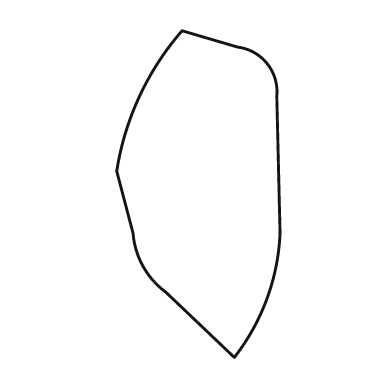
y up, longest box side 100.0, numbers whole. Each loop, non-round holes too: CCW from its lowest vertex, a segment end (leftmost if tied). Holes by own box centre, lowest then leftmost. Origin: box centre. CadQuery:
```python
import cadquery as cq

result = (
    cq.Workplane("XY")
    .moveTo(11.0, -50.0)
    .threePointArc((21.0, -32.0), (25.0, -12.0))
    .lineTo(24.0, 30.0)
    .threePointArc((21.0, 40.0), (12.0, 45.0))
    .lineTo(-5.0, 50.0)
    .threePointArc((-18.0, 30.0), (-25.0, 7.0))
    .lineTo(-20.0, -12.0)
    .threePointArc((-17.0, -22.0), (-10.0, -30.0))
    .close()
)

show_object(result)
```